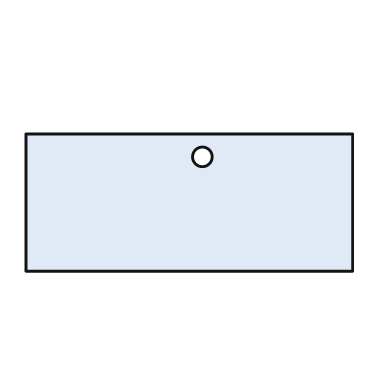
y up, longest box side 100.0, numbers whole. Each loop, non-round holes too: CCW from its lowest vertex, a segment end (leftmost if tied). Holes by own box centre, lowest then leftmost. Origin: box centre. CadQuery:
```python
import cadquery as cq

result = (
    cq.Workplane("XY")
    .moveTo(-50.0, -21.0)
    .lineTo(50.0, -21.0)
    .lineTo(50.0, 21.0)
    .lineTo(-50.0, 21.0)
    .close()
    .moveTo(4.0, 14.0)
    .circle(3.0)
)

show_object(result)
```